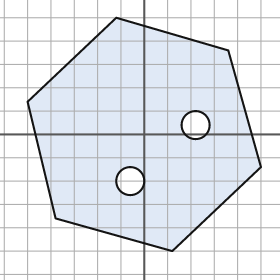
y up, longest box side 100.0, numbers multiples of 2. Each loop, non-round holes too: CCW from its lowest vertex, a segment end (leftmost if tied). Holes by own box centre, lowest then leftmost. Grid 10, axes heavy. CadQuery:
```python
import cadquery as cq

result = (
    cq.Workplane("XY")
    .moveTo(12.0, -50.0)
    .lineTo(50.0, -14.0)
    .lineTo(36.0, 36.0)
    .lineTo(-12.0, 50.0)
    .lineTo(-50.0, 14.0)
    .lineTo(-38.0, -36.0)
    .close()
    .moveTo(-6.0, -20.0)
    .circle(6.0)
    .moveTo(22.0, 4.0)
    .circle(6.0)
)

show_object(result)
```